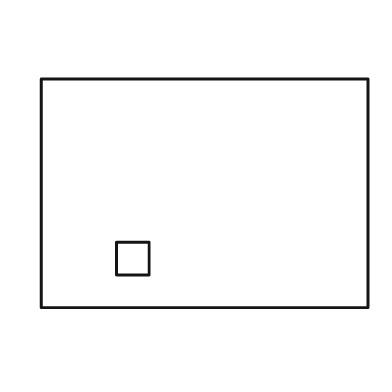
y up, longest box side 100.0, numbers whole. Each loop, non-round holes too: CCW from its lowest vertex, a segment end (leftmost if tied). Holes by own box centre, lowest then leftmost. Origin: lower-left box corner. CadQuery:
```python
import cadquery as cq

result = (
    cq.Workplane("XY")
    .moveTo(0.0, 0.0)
    .lineTo(100.0, 0.0)
    .lineTo(100.0, 70.0)
    .lineTo(0.0, 70.0)
    .close()
    .moveTo(23.0, 10.0)
    .lineTo(33.0, 10.0)
    .lineTo(33.0, 20.0)
    .lineTo(23.0, 20.0)
    .close()
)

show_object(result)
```